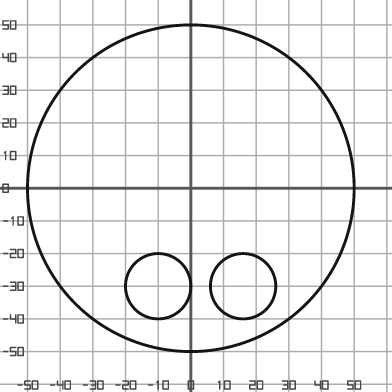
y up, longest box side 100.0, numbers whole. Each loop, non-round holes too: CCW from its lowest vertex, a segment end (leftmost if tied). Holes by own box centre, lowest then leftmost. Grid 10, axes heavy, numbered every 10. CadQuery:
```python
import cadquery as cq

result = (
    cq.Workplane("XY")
    .moveTo(0.0, 0.0)
    .circle(50.0)
    .moveTo(-10.0, -30.0)
    .circle(10.0)
    .moveTo(16.0, -30.0)
    .circle(10.0)
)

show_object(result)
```